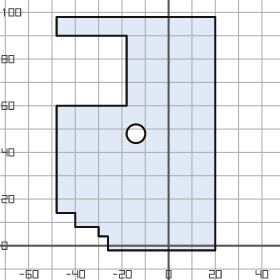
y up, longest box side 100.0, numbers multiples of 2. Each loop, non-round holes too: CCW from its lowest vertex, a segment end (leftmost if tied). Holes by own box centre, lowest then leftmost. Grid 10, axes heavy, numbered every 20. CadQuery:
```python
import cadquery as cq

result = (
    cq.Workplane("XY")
    .moveTo(-26.0, -2.0)
    .lineTo(20.0, -2.0)
    .lineTo(20.0, 98.0)
    .lineTo(-48.0, 98.0)
    .lineTo(-48.0, 90.0)
    .lineTo(-18.0, 90.0)
    .lineTo(-18.0, 60.0)
    .lineTo(-48.0, 60.0)
    .lineTo(-48.0, 14.0)
    .lineTo(-40.0, 14.0)
    .lineTo(-40.0, 8.0)
    .lineTo(-30.0, 8.0)
    .lineTo(-30.0, 4.0)
    .lineTo(-26.0, 4.0)
    .close()
    .moveTo(-14.0, 48.0)
    .circle(4.0)
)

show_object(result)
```